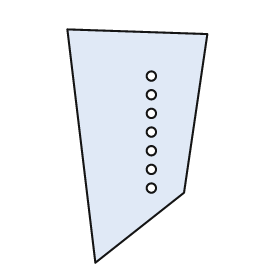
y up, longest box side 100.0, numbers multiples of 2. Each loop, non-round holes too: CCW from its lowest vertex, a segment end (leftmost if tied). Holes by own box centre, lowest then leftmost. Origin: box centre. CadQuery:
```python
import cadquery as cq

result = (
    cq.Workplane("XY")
    .moveTo(-18.0, -50.0)
    .lineTo(20.0, -20.0)
    .lineTo(30.0, 48.0)
    .lineTo(-30.0, 50.0)
    .close()
    .moveTo(6.0, -18.0)
    .circle(2.0)
    .moveTo(6.0, -10.0)
    .circle(2.0)
    .moveTo(6.0, -2.0)
    .circle(2.0)
    .moveTo(6.0, 6.0)
    .circle(2.0)
    .moveTo(6.0, 14.0)
    .circle(2.0)
    .moveTo(6.0, 22.0)
    .circle(2.0)
    .moveTo(6.0, 30.0)
    .circle(2.0)
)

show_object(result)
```